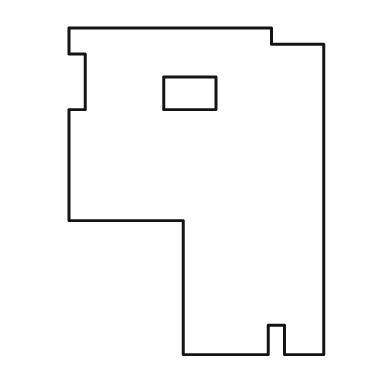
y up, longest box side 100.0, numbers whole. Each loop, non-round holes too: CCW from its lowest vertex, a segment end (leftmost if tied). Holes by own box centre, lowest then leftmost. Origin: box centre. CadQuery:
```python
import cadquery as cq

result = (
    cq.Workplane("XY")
    .moveTo(-4.0, -50.0)
    .lineTo(22.0, -50.0)
    .lineTo(22.0, -41.0)
    .lineTo(27.0, -41.0)
    .lineTo(27.0, -50.0)
    .lineTo(39.0, -50.0)
    .lineTo(39.0, 45.0)
    .lineTo(23.0, 45.0)
    .lineTo(23.0, 50.0)
    .lineTo(-39.0, 50.0)
    .lineTo(-39.0, 42.0)
    .lineTo(-34.0, 42.0)
    .lineTo(-34.0, 25.0)
    .lineTo(-39.0, 25.0)
    .lineTo(-39.0, -9.0)
    .lineTo(-4.0, -9.0)
    .close()
    .moveTo(-10.0, 25.0)
    .lineTo(6.0, 25.0)
    .lineTo(6.0, 35.0)
    .lineTo(-10.0, 35.0)
    .close()
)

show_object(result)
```